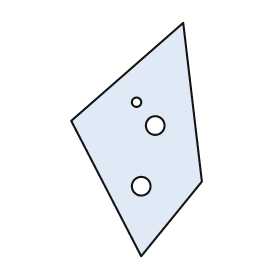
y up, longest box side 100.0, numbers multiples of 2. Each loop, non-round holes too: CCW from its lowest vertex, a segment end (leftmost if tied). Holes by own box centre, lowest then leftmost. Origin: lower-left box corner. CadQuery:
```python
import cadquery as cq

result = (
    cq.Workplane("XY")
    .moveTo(30.0, 0.0)
    .lineTo(56.0, 32.0)
    .lineTo(48.0, 100.0)
    .lineTo(0.0, 58.0)
    .close()
    .moveTo(30.0, 30.0)
    .circle(4.0)
    .moveTo(36.0, 56.0)
    .circle(4.0)
    .moveTo(28.0, 66.0)
    .circle(2.0)
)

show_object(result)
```